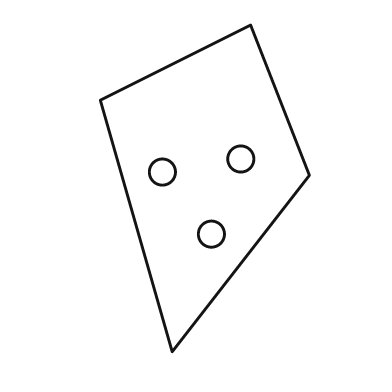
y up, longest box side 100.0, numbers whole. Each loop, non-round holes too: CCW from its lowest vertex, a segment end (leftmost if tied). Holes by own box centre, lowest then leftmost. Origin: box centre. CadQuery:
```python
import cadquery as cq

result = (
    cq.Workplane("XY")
    .moveTo(-10.0, -50.0)
    .lineTo(32.0, 4.0)
    .lineTo(14.0, 50.0)
    .lineTo(-32.0, 27.0)
    .close()
    .moveTo(2.0, -14.0)
    .circle(4.0)
    .moveTo(-13.0, 5.0)
    .circle(4.0)
    .moveTo(11.0, 9.0)
    .circle(4.0)
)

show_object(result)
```